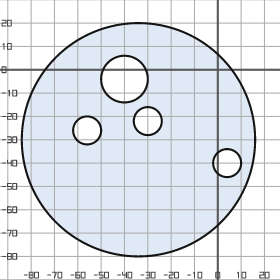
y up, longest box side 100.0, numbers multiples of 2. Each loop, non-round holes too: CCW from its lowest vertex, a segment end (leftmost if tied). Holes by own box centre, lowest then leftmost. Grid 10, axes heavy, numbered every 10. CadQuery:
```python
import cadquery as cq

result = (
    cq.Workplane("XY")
    .moveTo(-34.0, -30.0)
    .circle(50.0)
    .moveTo(4.0, -40.0)
    .circle(6.0)
    .moveTo(-56.0, -26.0)
    .circle(6.0)
    .moveTo(-30.0, -22.0)
    .circle(6.0)
    .moveTo(-40.0, -4.0)
    .circle(10.0)
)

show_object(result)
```